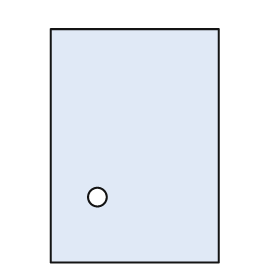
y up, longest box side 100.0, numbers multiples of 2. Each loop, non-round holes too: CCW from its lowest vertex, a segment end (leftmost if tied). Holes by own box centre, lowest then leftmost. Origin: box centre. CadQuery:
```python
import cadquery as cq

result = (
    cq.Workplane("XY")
    .moveTo(-36.0, -50.0)
    .lineTo(36.0, -50.0)
    .lineTo(36.0, 50.0)
    .lineTo(-36.0, 50.0)
    .close()
    .moveTo(-16.0, -22.0)
    .circle(4.0)
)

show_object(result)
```